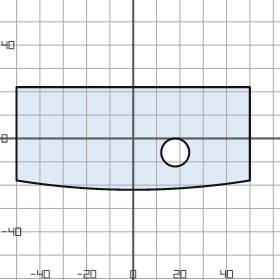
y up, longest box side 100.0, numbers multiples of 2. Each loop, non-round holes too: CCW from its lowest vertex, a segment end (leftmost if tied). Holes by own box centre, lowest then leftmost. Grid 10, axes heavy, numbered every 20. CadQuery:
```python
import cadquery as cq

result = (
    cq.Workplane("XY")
    .moveTo(-50.0, -18.0)
    .threePointArc((0.0, -22.0), (50.0, -18.0))
    .lineTo(50.0, 22.0)
    .lineTo(-50.0, 22.0)
    .close()
    .moveTo(18.0, -6.0)
    .circle(6.0)
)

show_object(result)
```